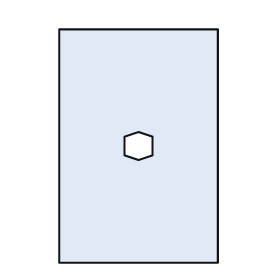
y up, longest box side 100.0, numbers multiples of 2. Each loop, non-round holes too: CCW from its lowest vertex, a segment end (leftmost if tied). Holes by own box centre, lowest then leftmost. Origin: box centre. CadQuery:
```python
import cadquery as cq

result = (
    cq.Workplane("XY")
    .moveTo(-34.0, -50.0)
    .lineTo(34.0, -50.0)
    .lineTo(34.0, 50.0)
    .lineTo(-34.0, 50.0)
    .close()
    .moveTo(0.0, -6.0)
    .lineTo(6.0, -4.0)
    .lineTo(6.0, 4.0)
    .lineTo(0.0, 6.0)
    .lineTo(-6.0, 4.0)
    .lineTo(-6.0, -4.0)
    .close()
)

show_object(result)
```